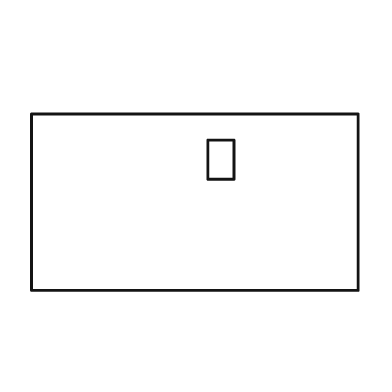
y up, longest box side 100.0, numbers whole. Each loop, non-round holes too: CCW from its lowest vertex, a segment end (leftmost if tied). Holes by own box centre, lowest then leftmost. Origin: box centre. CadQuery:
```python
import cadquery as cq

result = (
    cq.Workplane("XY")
    .moveTo(-50.0, -27.0)
    .lineTo(50.0, -27.0)
    .lineTo(50.0, 27.0)
    .lineTo(-50.0, 27.0)
    .close()
    .moveTo(4.0, 7.0)
    .lineTo(12.0, 7.0)
    .lineTo(12.0, 19.0)
    .lineTo(4.0, 19.0)
    .close()
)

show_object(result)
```